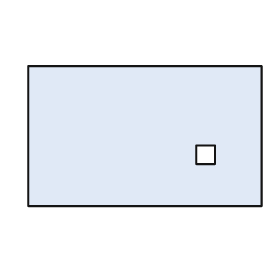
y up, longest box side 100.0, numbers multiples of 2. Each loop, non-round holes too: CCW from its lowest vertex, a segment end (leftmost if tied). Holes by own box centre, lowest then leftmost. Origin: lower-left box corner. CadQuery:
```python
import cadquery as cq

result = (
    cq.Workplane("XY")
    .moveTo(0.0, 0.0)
    .lineTo(100.0, 0.0)
    .lineTo(100.0, 60.0)
    .lineTo(0.0, 60.0)
    .close()
    .moveTo(72.0, 18.0)
    .lineTo(80.0, 18.0)
    .lineTo(80.0, 26.0)
    .lineTo(72.0, 26.0)
    .close()
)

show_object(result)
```